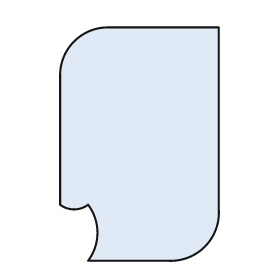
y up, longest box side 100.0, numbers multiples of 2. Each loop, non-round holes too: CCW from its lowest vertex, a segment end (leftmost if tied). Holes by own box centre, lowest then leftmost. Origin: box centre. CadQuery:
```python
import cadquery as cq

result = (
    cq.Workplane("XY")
    .moveTo(-22.0, -50.0)
    .lineTo(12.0, -50.0)
    .threePointArc((28.0, -44.0), (34.0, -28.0))
    .lineTo(34.0, 50.0)
    .lineTo(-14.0, 50.0)
    .threePointArc((-28.0, 44.0), (-34.0, 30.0))
    .lineTo(-34.0, -26.0)
    .threePointArc((-28.0, -28.0), (-22.0, -26.0))
    .threePointArc((-18.0, -38.0), (-22.0, -50.0))
    .close()
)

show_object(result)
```